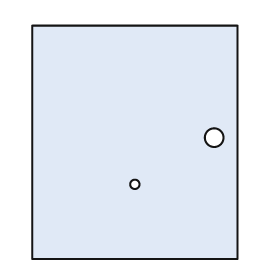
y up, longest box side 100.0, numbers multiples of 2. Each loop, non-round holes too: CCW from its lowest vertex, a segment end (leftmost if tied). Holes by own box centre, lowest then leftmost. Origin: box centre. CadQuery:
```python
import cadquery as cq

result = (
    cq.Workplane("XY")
    .moveTo(-44.0, -50.0)
    .lineTo(44.0, -50.0)
    .lineTo(44.0, 50.0)
    .lineTo(-44.0, 50.0)
    .close()
    .moveTo(0.0, -18.0)
    .circle(2.0)
    .moveTo(34.0, 2.0)
    .circle(4.0)
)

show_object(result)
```